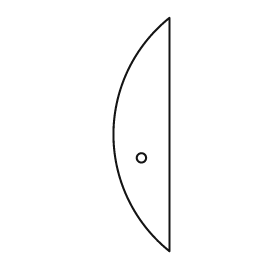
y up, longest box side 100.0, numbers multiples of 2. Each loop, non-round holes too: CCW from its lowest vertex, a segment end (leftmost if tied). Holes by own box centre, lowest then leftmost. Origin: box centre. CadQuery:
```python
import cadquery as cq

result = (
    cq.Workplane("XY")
    .moveTo(12.0, -50.0)
    .lineTo(12.0, 50.0)
    .threePointArc((-12.0, 0.0), (12.0, -50.0))
    .close()
    .moveTo(0.0, -10.0)
    .circle(2.0)
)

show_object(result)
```